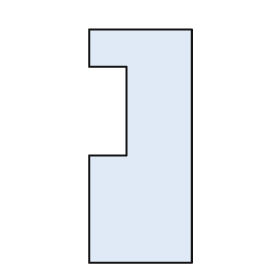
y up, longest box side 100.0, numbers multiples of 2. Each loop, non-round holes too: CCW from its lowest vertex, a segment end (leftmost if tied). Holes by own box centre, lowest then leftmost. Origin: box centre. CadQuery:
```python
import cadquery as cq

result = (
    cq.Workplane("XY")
    .moveTo(-22.0, -50.0)
    .lineTo(22.0, -50.0)
    .lineTo(22.0, 50.0)
    .lineTo(-22.0, 50.0)
    .lineTo(-22.0, 34.0)
    .lineTo(-6.0, 34.0)
    .lineTo(-6.0, -4.0)
    .lineTo(-22.0, -4.0)
    .close()
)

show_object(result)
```